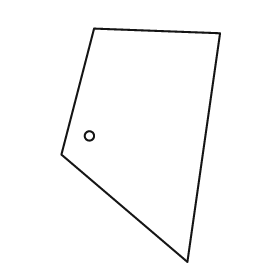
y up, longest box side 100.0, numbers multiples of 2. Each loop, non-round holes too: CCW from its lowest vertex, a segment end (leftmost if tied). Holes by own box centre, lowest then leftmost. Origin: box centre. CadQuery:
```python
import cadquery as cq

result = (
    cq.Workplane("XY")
    .moveTo(20.0, -50.0)
    .lineTo(34.0, 48.0)
    .lineTo(-20.0, 50.0)
    .lineTo(-34.0, -4.0)
    .close()
    .moveTo(-22.0, 4.0)
    .circle(2.0)
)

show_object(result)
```